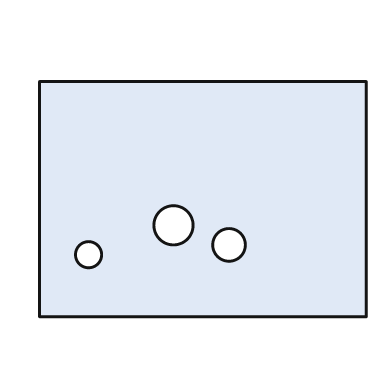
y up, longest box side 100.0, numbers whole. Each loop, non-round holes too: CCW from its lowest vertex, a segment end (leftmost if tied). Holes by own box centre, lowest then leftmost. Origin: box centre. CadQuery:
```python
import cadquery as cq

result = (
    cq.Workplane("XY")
    .moveTo(-50.0, -36.0)
    .lineTo(50.0, -36.0)
    .lineTo(50.0, 36.0)
    .lineTo(-50.0, 36.0)
    .close()
    .moveTo(-35.0, -17.0)
    .circle(4.0)
    .moveTo(8.0, -14.0)
    .circle(5.0)
    .moveTo(-9.0, -8.0)
    .circle(6.0)
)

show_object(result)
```